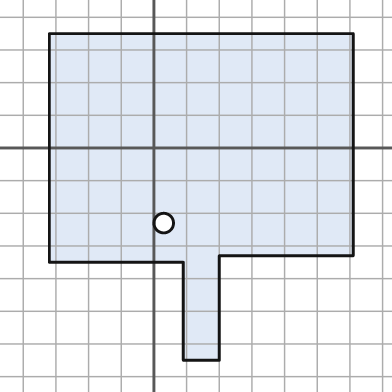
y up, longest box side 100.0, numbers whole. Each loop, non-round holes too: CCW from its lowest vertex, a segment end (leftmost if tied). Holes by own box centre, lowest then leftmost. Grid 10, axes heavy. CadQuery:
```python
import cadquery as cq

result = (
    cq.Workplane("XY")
    .moveTo(9.0, -65.0)
    .lineTo(20.0, -65.0)
    .lineTo(20.0, -33.0)
    .lineTo(61.0, -33.0)
    .lineTo(61.0, 35.0)
    .lineTo(-32.0, 35.0)
    .lineTo(-32.0, -35.0)
    .lineTo(9.0, -35.0)
    .close()
    .moveTo(3.0, -23.0)
    .circle(3.0)
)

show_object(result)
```